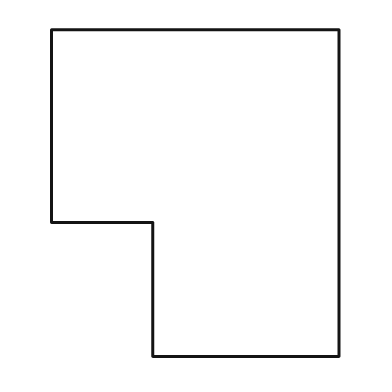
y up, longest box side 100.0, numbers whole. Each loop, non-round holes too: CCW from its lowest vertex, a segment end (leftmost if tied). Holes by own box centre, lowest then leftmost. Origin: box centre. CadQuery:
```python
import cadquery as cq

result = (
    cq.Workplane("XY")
    .moveTo(-13.0, -50.0)
    .lineTo(44.0, -50.0)
    .lineTo(44.0, 50.0)
    .lineTo(-44.0, 50.0)
    .lineTo(-44.0, -9.0)
    .lineTo(-13.0, -9.0)
    .close()
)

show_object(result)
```